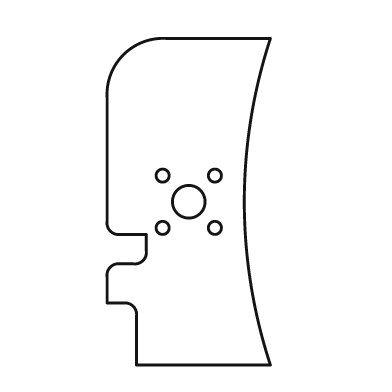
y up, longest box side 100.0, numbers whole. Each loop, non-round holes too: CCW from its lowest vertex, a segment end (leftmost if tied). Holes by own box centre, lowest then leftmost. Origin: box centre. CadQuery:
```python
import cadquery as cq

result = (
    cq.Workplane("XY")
    .moveTo(-16.0, -50.0)
    .lineTo(25.0, -50.0)
    .threePointArc((17.0, 0.0), (25.0, 50.0))
    .lineTo(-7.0, 50.0)
    .threePointArc((-20.0, 45.0), (-25.0, 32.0))
    .lineTo(-25.0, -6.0)
    .threePointArc((-24.0, -9.0), (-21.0, -10.0))
    .lineTo(-13.0, -10.0)
    .lineTo(-13.0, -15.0)
    .threePointArc((-14.0, -18.0), (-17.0, -19.0))
    .lineTo(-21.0, -19.0)
    .threePointArc((-24.0, -20.0), (-25.0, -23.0))
    .lineTo(-25.0, -31.0)
    .lineTo(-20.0, -31.0)
    .threePointArc((-17.0, -32.0), (-16.0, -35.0))
    .close()
    .moveTo(-8.0, -8.0)
    .circle(2.0)
    .moveTo(8.0, -8.0)
    .circle(2.0)
    .moveTo(0.0, 0.0)
    .circle(5.0)
    .moveTo(-8.0, 8.0)
    .circle(2.0)
    .moveTo(8.0, 8.0)
    .circle(2.0)
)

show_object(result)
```